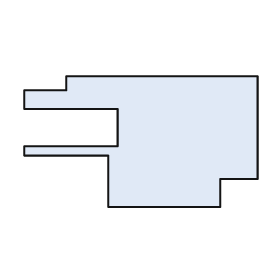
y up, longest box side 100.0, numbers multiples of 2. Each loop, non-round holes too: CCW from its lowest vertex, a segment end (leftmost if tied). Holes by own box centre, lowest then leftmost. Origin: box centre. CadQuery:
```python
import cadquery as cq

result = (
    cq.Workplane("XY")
    .moveTo(-14.0, -28.0)
    .lineTo(34.0, -28.0)
    .lineTo(34.0, -16.0)
    .lineTo(50.0, -16.0)
    .lineTo(50.0, 28.0)
    .lineTo(-32.0, 28.0)
    .lineTo(-32.0, 22.0)
    .lineTo(-50.0, 22.0)
    .lineTo(-50.0, 14.0)
    .lineTo(-10.0, 14.0)
    .lineTo(-10.0, -2.0)
    .lineTo(-50.0, -2.0)
    .lineTo(-50.0, -6.0)
    .lineTo(-14.0, -6.0)
    .close()
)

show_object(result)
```